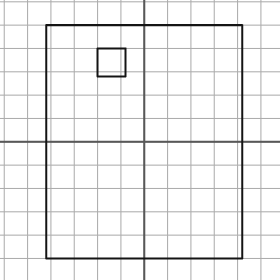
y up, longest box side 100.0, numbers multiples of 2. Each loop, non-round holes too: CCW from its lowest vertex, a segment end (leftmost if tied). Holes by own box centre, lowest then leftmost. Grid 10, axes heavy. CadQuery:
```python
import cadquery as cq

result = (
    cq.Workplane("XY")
    .moveTo(-42.0, -50.0)
    .lineTo(42.0, -50.0)
    .lineTo(42.0, 50.0)
    .lineTo(-42.0, 50.0)
    .close()
    .moveTo(-20.0, 28.0)
    .lineTo(-8.0, 28.0)
    .lineTo(-8.0, 40.0)
    .lineTo(-20.0, 40.0)
    .close()
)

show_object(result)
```